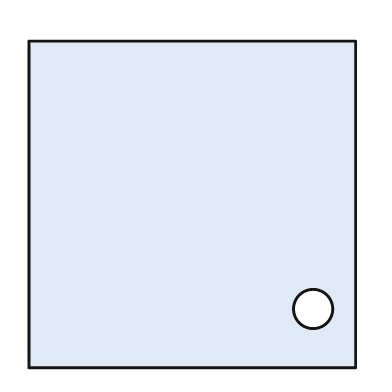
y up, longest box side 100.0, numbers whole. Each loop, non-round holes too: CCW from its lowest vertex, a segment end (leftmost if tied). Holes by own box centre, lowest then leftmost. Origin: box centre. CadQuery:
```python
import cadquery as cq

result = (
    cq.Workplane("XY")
    .moveTo(-50.0, -50.0)
    .lineTo(50.0, -50.0)
    .lineTo(50.0, 50.0)
    .lineTo(-50.0, 50.0)
    .close()
    .moveTo(37.0, -32.0)
    .circle(6.0)
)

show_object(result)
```